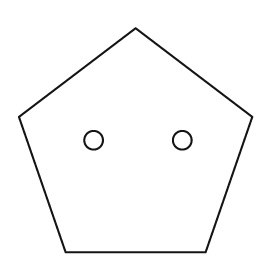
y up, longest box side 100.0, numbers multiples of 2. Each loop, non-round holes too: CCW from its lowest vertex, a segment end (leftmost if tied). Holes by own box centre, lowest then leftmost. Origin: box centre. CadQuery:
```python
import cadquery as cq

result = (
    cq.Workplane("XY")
    .moveTo(-30.0, -48.0)
    .lineTo(30.0, -48.0)
    .lineTo(50.0, 10.0)
    .lineTo(0.0, 48.0)
    .lineTo(-50.0, 10.0)
    .close()
    .moveTo(-18.0, 0.0)
    .circle(4.0)
    .moveTo(20.0, 0.0)
    .circle(4.0)
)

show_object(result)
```